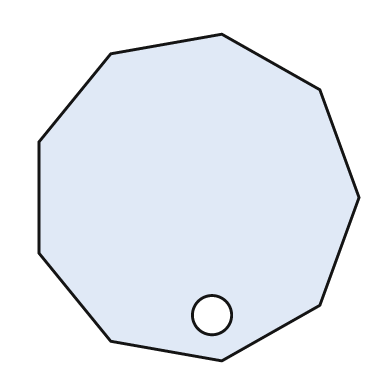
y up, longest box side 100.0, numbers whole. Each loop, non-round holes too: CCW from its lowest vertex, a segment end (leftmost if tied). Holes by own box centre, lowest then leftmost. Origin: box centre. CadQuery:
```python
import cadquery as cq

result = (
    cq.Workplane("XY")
    .moveTo(7.0, -50.0)
    .lineTo(37.0, -33.0)
    .lineTo(49.0, 0.0)
    .lineTo(37.0, 33.0)
    .lineTo(7.0, 50.0)
    .lineTo(-27.0, 44.0)
    .lineTo(-49.0, 17.0)
    .lineTo(-49.0, -17.0)
    .lineTo(-27.0, -44.0)
    .close()
    .moveTo(4.0, -36.0)
    .circle(6.0)
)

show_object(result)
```